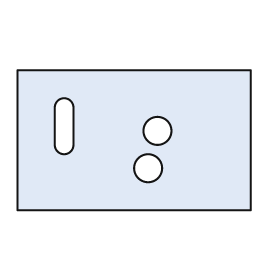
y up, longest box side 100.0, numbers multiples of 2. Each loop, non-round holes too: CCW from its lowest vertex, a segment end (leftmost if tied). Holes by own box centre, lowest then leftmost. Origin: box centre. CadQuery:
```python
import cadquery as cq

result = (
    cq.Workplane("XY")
    .moveTo(-50.0, -30.0)
    .lineTo(50.0, -30.0)
    .lineTo(50.0, 30.0)
    .lineTo(-50.0, 30.0)
    .close()
    .moveTo(6.0, -12.0)
    .circle(6.0)
    .moveTo(10.0, 4.0)
    .circle(6.0)
    .moveTo(-34.0, -2.0)
    .threePointArc((-30.0, -6.0), (-26.0, -2.0))
    .lineTo(-26.0, 14.0)
    .threePointArc((-30.0, 18.0), (-34.0, 14.0))
    .close()
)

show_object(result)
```